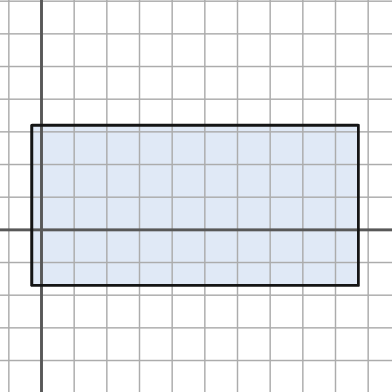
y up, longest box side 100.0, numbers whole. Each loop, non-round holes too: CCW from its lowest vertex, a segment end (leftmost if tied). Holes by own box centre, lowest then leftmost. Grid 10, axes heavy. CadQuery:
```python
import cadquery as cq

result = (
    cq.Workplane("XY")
    .moveTo(-3.0, -17.0)
    .lineTo(97.0, -17.0)
    .lineTo(97.0, 32.0)
    .lineTo(-3.0, 32.0)
    .close()
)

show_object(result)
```